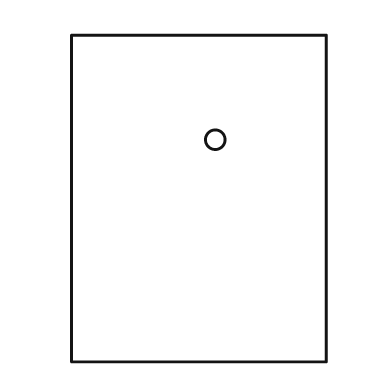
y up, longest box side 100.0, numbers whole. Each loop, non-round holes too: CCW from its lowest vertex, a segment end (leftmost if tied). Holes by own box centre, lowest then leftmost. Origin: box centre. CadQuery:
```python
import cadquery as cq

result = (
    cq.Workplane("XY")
    .moveTo(-39.0, -50.0)
    .lineTo(39.0, -50.0)
    .lineTo(39.0, 50.0)
    .lineTo(-39.0, 50.0)
    .close()
    .moveTo(5.0, 18.0)
    .circle(3.0)
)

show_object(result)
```